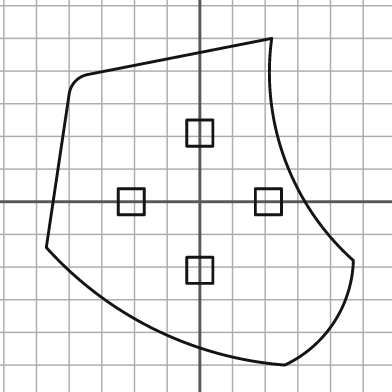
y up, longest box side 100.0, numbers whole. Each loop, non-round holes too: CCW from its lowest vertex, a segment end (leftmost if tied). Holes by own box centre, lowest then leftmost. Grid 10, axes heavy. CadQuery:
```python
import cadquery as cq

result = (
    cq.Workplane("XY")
    .moveTo(26.0, -50.0)
    .threePointArc((41.0, -37.0), (47.0, -18.0))
    .threePointArc((26.0, 13.0), (22.0, 50.0))
    .lineTo(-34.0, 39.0)
    .threePointArc((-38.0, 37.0), (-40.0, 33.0))
    .lineTo(-47.0, -14.0)
    .threePointArc((-14.0, -39.0), (26.0, -50.0))
    .close()
    .moveTo(-4.0, -25.0)
    .lineTo(4.0, -25.0)
    .lineTo(4.0, -17.0)
    .lineTo(-4.0, -17.0)
    .close()
    .moveTo(-25.0, -4.0)
    .lineTo(-17.0, -4.0)
    .lineTo(-17.0, 4.0)
    .lineTo(-25.0, 4.0)
    .close()
    .moveTo(17.0, -4.0)
    .lineTo(25.0, -4.0)
    .lineTo(25.0, 4.0)
    .lineTo(17.0, 4.0)
    .close()
    .moveTo(-4.0, 17.0)
    .lineTo(4.0, 17.0)
    .lineTo(4.0, 25.0)
    .lineTo(-4.0, 25.0)
    .close()
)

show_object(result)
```